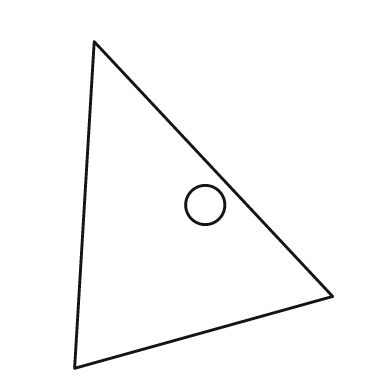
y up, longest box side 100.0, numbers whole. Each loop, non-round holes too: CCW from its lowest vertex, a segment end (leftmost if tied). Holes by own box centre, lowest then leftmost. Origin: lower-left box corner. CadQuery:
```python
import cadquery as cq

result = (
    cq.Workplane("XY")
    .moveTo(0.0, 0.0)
    .lineTo(79.0, 22.0)
    .lineTo(6.0, 100.0)
    .close()
    .moveTo(40.0, 50.0)
    .circle(6.0)
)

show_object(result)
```